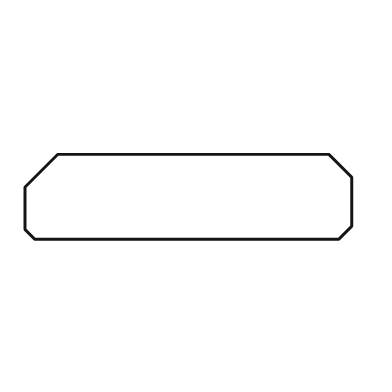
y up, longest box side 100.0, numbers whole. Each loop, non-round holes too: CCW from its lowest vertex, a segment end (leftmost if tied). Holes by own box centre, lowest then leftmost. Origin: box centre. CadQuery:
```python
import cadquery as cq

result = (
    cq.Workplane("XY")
    .moveTo(-47.0, -13.0)
    .lineTo(46.0, -13.0)
    .lineTo(50.0, -9.0)
    .lineTo(50.0, 6.0)
    .lineTo(43.0, 13.0)
    .lineTo(-40.0, 13.0)
    .lineTo(-50.0, 3.0)
    .lineTo(-50.0, -10.0)
    .close()
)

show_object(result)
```